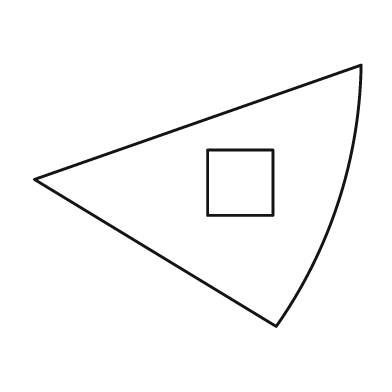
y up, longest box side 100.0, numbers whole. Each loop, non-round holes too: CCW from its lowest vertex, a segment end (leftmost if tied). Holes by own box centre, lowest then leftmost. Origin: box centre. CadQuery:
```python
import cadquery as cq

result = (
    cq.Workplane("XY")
    .moveTo(24.0, -40.0)
    .threePointArc((43.0, -2.0), (50.0, 40.0))
    .lineTo(-50.0, 5.0)
    .close()
    .moveTo(3.0, -6.0)
    .lineTo(23.0, -6.0)
    .lineTo(23.0, 14.0)
    .lineTo(3.0, 14.0)
    .close()
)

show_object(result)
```